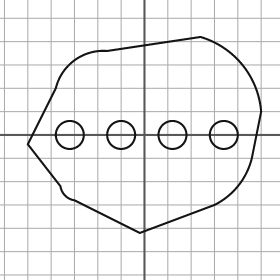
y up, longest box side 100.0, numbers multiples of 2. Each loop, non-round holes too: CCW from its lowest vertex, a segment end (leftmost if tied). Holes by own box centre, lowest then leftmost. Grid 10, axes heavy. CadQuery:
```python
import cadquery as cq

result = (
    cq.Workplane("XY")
    .moveTo(-2.0, -42.0)
    .lineTo(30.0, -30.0)
    .threePointArc((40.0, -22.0), (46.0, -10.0))
    .lineTo(50.0, 10.0)
    .threePointArc((42.0, 30.0), (24.0, 42.0))
    .lineTo(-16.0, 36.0)
    .threePointArc((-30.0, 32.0), (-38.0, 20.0))
    .lineTo(-50.0, -4.0)
    .lineTo(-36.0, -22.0)
    .threePointArc((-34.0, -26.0), (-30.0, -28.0))
    .close()
    .moveTo(-32.0, 0.0)
    .circle(6.0)
    .moveTo(-10.0, 0.0)
    .circle(6.0)
    .moveTo(12.0, 0.0)
    .circle(6.0)
    .moveTo(34.0, 0.0)
    .circle(6.0)
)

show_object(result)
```